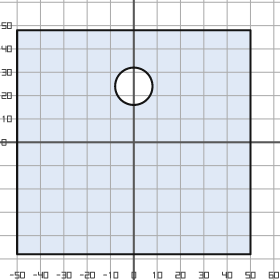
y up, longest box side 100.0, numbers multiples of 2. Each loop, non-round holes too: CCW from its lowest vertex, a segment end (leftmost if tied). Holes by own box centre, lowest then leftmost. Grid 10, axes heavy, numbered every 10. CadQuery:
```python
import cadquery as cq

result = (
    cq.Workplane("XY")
    .moveTo(-50.0, -48.0)
    .lineTo(50.0, -48.0)
    .lineTo(50.0, 48.0)
    .lineTo(-50.0, 48.0)
    .close()
    .moveTo(0.0, 24.0)
    .circle(8.0)
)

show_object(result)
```